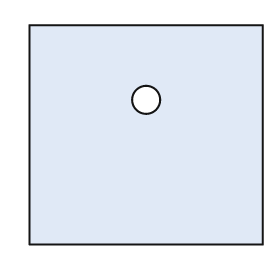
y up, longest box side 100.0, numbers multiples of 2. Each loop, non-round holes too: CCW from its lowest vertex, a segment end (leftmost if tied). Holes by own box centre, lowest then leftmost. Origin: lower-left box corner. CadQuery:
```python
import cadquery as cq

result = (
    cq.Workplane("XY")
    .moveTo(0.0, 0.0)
    .lineTo(100.0, 0.0)
    .lineTo(100.0, 94.0)
    .lineTo(0.0, 94.0)
    .close()
    .moveTo(50.0, 62.0)
    .circle(6.0)
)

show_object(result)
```